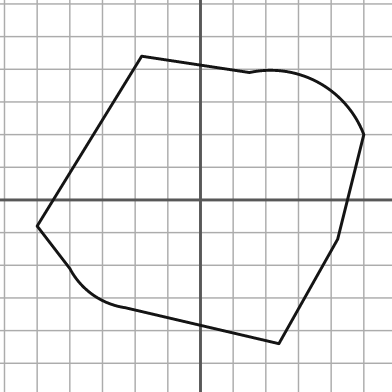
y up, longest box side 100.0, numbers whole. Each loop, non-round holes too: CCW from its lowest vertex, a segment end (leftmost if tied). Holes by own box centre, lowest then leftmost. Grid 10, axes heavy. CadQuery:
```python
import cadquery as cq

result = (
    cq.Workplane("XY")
    .moveTo(24.0, -44.0)
    .lineTo(42.0, -12.0)
    .lineTo(50.0, 20.0)
    .threePointArc((36.0, 36.0), (15.0, 39.0))
    .lineTo(-18.0, 44.0)
    .lineTo(-50.0, -8.0)
    .lineTo(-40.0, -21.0)
    .threePointArc((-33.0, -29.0), (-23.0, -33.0))
    .close()
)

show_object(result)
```